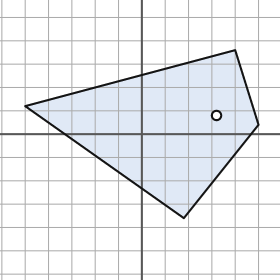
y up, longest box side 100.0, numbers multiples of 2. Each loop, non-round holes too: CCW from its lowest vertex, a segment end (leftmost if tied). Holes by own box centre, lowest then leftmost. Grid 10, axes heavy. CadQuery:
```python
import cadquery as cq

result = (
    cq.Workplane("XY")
    .moveTo(18.0, -36.0)
    .lineTo(50.0, 4.0)
    .lineTo(40.0, 36.0)
    .lineTo(-50.0, 12.0)
    .close()
    .moveTo(32.0, 8.0)
    .circle(2.0)
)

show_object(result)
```